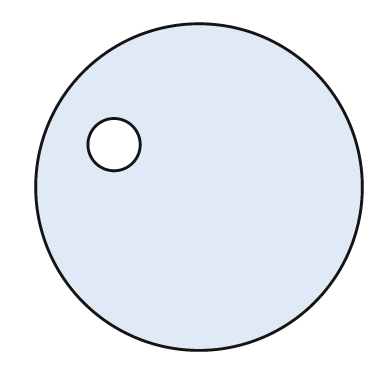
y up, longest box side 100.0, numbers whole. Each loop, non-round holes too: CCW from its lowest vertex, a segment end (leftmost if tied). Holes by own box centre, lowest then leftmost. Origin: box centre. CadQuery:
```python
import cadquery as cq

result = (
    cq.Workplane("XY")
    .moveTo(0.0, 0.0)
    .circle(50.0)
    .moveTo(-26.0, 13.0)
    .circle(8.0)
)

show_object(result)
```